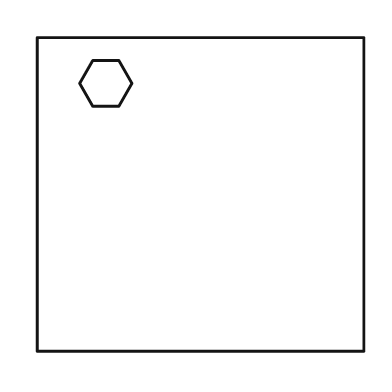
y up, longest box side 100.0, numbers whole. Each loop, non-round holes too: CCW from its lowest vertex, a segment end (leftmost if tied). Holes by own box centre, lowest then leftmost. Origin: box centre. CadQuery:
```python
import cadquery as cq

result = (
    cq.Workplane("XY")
    .moveTo(-50.0, -48.0)
    .lineTo(50.0, -48.0)
    .lineTo(50.0, 48.0)
    .lineTo(-50.0, 48.0)
    .close()
    .moveTo(-33.0, 27.0)
    .lineTo(-25.0, 27.0)
    .lineTo(-21.0, 34.0)
    .lineTo(-25.0, 41.0)
    .lineTo(-33.0, 41.0)
    .lineTo(-37.0, 34.0)
    .close()
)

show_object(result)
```